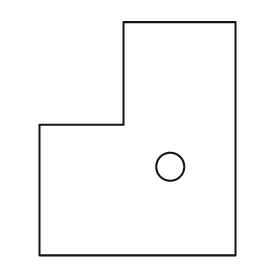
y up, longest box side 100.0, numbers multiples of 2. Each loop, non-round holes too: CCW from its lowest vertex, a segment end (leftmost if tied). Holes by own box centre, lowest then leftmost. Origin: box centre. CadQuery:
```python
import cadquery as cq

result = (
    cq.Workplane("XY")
    .moveTo(-42.0, -50.0)
    .lineTo(42.0, -50.0)
    .lineTo(42.0, 50.0)
    .lineTo(-6.0, 50.0)
    .lineTo(-6.0, 6.0)
    .lineTo(-42.0, 6.0)
    .close()
    .moveTo(14.0, -12.0)
    .circle(6.0)
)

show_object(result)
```